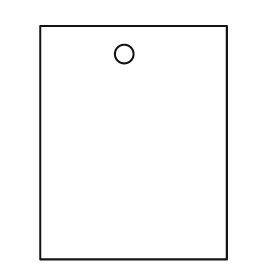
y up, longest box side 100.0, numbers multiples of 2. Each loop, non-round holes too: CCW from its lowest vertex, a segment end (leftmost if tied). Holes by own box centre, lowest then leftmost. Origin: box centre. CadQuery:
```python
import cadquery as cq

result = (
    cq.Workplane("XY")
    .moveTo(-40.0, -50.0)
    .lineTo(40.0, -50.0)
    .lineTo(40.0, 50.0)
    .lineTo(-40.0, 50.0)
    .close()
    .moveTo(-4.0, 38.0)
    .circle(4.0)
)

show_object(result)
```